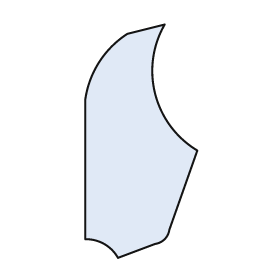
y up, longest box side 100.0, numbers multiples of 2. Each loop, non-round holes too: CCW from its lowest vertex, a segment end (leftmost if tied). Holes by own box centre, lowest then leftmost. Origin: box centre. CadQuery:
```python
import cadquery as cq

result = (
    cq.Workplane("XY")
    .moveTo(-10.0, -50.0)
    .lineTo(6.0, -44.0)
    .threePointArc((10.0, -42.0), (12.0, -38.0))
    .lineTo(24.0, -4.0)
    .threePointArc((6.0, 20.0), (10.0, 50.0))
    .lineTo(-6.0, 46.0)
    .threePointArc((-18.0, 34.0), (-24.0, 18.0))
    .lineTo(-24.0, -42.0)
    .threePointArc((-16.0, -44.0), (-10.0, -50.0))
    .close()
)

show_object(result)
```